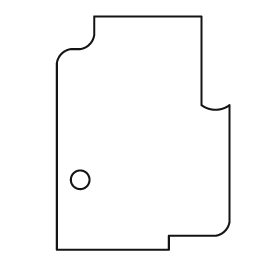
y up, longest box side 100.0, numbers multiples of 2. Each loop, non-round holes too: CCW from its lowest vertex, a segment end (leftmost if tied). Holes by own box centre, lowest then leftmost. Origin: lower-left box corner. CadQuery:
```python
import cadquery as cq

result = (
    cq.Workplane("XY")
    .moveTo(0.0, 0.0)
    .lineTo(48.0, 0.0)
    .lineTo(48.0, 6.0)
    .lineTo(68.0, 6.0)
    .threePointArc((72.0, 8.0), (74.0, 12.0))
    .lineTo(74.0, 62.0)
    .threePointArc((68.0, 60.0), (62.0, 62.0))
    .lineTo(62.0, 100.0)
    .lineTo(16.0, 100.0)
    .lineTo(16.0, 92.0)
    .threePointArc((14.0, 88.0), (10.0, 86.0))
    .lineTo(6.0, 86.0)
    .threePointArc((2.0, 84.0), (0.0, 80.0))
    .close()
    .moveTo(10.0, 30.0)
    .circle(4.0)
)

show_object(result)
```